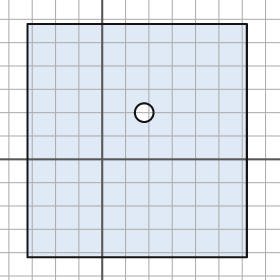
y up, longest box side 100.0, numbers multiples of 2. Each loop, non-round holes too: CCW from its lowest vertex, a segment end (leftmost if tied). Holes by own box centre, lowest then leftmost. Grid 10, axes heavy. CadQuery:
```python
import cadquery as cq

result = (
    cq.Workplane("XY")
    .moveTo(-32.0, -42.0)
    .lineTo(62.0, -42.0)
    .lineTo(62.0, 58.0)
    .lineTo(-32.0, 58.0)
    .close()
    .moveTo(18.0, 20.0)
    .circle(4.0)
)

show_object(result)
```